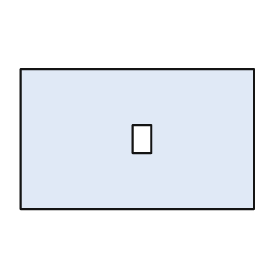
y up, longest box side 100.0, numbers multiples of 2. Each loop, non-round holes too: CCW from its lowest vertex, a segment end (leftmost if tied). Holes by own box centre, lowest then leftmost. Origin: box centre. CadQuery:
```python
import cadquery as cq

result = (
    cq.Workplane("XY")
    .moveTo(-50.0, -30.0)
    .lineTo(50.0, -30.0)
    .lineTo(50.0, 30.0)
    .lineTo(-50.0, 30.0)
    .close()
    .moveTo(-2.0, -6.0)
    .lineTo(6.0, -6.0)
    .lineTo(6.0, 6.0)
    .lineTo(-2.0, 6.0)
    .close()
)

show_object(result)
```